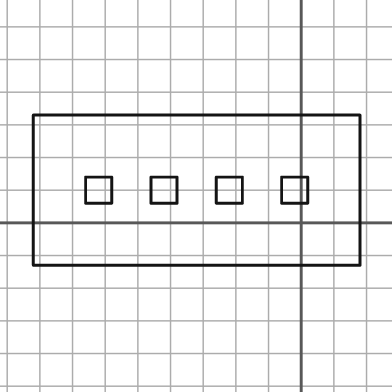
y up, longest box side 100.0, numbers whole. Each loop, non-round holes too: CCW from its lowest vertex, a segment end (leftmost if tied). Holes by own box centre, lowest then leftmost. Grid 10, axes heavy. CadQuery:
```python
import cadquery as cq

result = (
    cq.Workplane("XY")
    .moveTo(-82.0, -13.0)
    .lineTo(18.0, -13.0)
    .lineTo(18.0, 33.0)
    .lineTo(-82.0, 33.0)
    .close()
    .moveTo(-66.0, 6.0)
    .lineTo(-58.0, 6.0)
    .lineTo(-58.0, 14.0)
    .lineTo(-66.0, 14.0)
    .close()
    .moveTo(-46.0, 6.0)
    .lineTo(-38.0, 6.0)
    .lineTo(-38.0, 14.0)
    .lineTo(-46.0, 14.0)
    .close()
    .moveTo(-26.0, 6.0)
    .lineTo(-18.0, 6.0)
    .lineTo(-18.0, 14.0)
    .lineTo(-26.0, 14.0)
    .close()
    .moveTo(-6.0, 6.0)
    .lineTo(2.0, 6.0)
    .lineTo(2.0, 14.0)
    .lineTo(-6.0, 14.0)
    .close()
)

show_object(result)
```